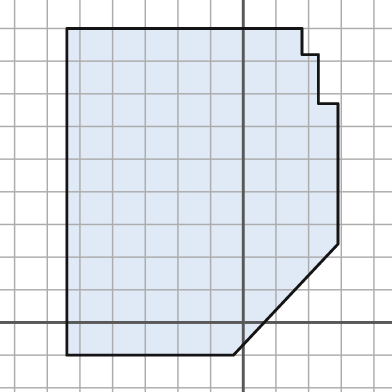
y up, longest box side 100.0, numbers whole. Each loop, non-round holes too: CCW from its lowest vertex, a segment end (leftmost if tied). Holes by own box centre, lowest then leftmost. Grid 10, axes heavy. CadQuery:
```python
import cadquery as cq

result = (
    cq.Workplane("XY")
    .moveTo(-54.0, -10.0)
    .lineTo(-3.0, -10.0)
    .lineTo(29.0, 24.0)
    .lineTo(29.0, 67.0)
    .lineTo(23.0, 67.0)
    .lineTo(23.0, 82.0)
    .lineTo(18.0, 82.0)
    .lineTo(18.0, 90.0)
    .lineTo(-54.0, 90.0)
    .close()
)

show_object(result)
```